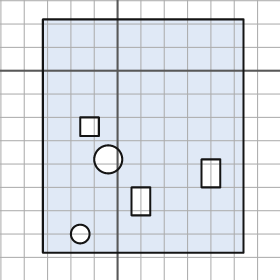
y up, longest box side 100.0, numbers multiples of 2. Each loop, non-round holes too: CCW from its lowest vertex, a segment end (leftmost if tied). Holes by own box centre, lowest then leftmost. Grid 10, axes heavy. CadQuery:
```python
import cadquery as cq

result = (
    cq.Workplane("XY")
    .moveTo(-32.0, -78.0)
    .lineTo(54.0, -78.0)
    .lineTo(54.0, 22.0)
    .lineTo(-32.0, 22.0)
    .close()
    .moveTo(-16.0, -70.0)
    .circle(4.0)
    .moveTo(6.0, -62.0)
    .lineTo(14.0, -62.0)
    .lineTo(14.0, -50.0)
    .lineTo(6.0, -50.0)
    .close()
    .moveTo(36.0, -50.0)
    .lineTo(44.0, -50.0)
    .lineTo(44.0, -38.0)
    .lineTo(36.0, -38.0)
    .close()
    .moveTo(-4.0, -38.0)
    .circle(6.0)
    .moveTo(-16.0, -28.0)
    .lineTo(-8.0, -28.0)
    .lineTo(-8.0, -20.0)
    .lineTo(-16.0, -20.0)
    .close()
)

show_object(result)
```